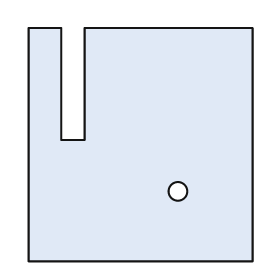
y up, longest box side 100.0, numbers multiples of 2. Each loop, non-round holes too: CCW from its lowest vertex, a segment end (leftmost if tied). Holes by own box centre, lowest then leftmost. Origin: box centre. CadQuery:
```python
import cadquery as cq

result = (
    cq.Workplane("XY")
    .moveTo(-48.0, -50.0)
    .lineTo(48.0, -50.0)
    .lineTo(48.0, 50.0)
    .lineTo(-24.0, 50.0)
    .lineTo(-24.0, 2.0)
    .lineTo(-34.0, 2.0)
    .lineTo(-34.0, 50.0)
    .lineTo(-48.0, 50.0)
    .close()
    .moveTo(16.0, -20.0)
    .circle(4.0)
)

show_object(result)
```